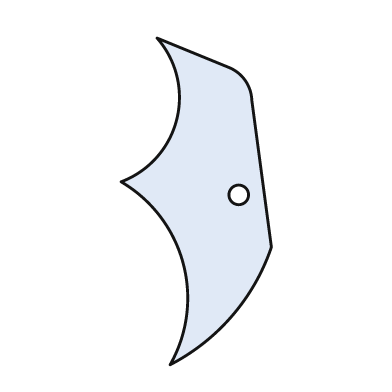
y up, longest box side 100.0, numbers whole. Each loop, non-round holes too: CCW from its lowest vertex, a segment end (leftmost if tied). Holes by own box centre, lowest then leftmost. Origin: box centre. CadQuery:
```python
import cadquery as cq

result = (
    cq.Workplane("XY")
    .moveTo(-8.0, -50.0)
    .threePointArc((11.0, -35.0), (23.0, -14.0))
    .lineTo(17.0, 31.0)
    .threePointArc((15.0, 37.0), (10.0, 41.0))
    .lineTo(-12.0, 50.0)
    .threePointArc((-6.0, 25.0), (-23.0, 6.0))
    .threePointArc((-4.0, -19.0), (-8.0, -50.0))
    .close()
    .moveTo(13.0, 2.0)
    .circle(3.0)
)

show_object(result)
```